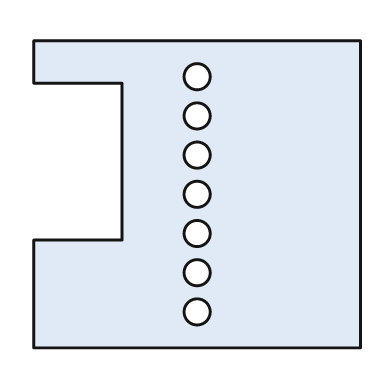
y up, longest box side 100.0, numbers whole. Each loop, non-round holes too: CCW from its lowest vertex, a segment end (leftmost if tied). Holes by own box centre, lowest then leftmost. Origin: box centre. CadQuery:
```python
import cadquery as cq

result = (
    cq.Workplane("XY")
    .moveTo(-50.0, -47.0)
    .lineTo(50.0, -47.0)
    .lineTo(50.0, 47.0)
    .lineTo(-50.0, 47.0)
    .lineTo(-50.0, 34.0)
    .lineTo(-23.0, 34.0)
    .lineTo(-23.0, -14.0)
    .lineTo(-50.0, -14.0)
    .close()
    .moveTo(0.0, -36.0)
    .circle(4.0)
    .moveTo(0.0, -24.0)
    .circle(4.0)
    .moveTo(0.0, -12.0)
    .circle(4.0)
    .moveTo(0.0, 0.0)
    .circle(4.0)
    .moveTo(0.0, 12.0)
    .circle(4.0)
    .moveTo(0.0, 24.0)
    .circle(4.0)
    .moveTo(0.0, 36.0)
    .circle(4.0)
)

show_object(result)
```